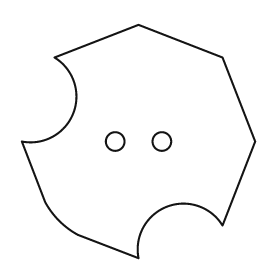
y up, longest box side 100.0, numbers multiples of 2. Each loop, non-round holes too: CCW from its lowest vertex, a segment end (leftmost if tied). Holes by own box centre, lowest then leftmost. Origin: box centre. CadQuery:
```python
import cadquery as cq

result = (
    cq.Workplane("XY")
    .moveTo(0.0, -50.0)
    .threePointArc((12.0, -28.0), (36.0, -36.0))
    .lineTo(50.0, 0.0)
    .lineTo(36.0, 36.0)
    .lineTo(0.0, 50.0)
    .lineTo(-36.0, 36.0)
    .threePointArc((-28.0, 12.0), (-50.0, 0.0))
    .lineTo(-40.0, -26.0)
    .threePointArc((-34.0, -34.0), (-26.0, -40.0))
    .close()
    .moveTo(-10.0, 0.0)
    .circle(4.0)
    .moveTo(10.0, 0.0)
    .circle(4.0)
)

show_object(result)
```